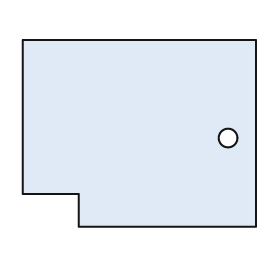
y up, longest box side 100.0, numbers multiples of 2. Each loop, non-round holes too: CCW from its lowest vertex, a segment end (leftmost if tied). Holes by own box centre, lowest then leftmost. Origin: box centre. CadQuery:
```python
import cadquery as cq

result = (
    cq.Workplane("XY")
    .moveTo(-26.0, -40.0)
    .lineTo(50.0, -40.0)
    .lineTo(50.0, 40.0)
    .lineTo(-50.0, 40.0)
    .lineTo(-50.0, -26.0)
    .lineTo(-26.0, -26.0)
    .close()
    .moveTo(38.0, -2.0)
    .circle(4.0)
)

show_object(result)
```